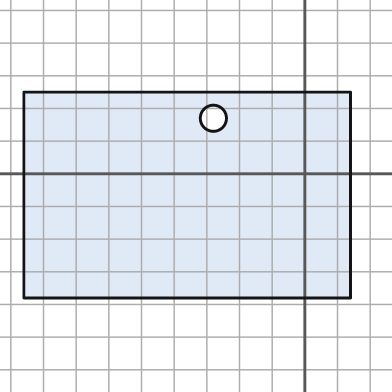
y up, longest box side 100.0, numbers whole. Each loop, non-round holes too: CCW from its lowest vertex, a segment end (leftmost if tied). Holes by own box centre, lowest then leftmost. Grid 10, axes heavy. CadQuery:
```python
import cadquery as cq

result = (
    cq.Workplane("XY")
    .moveTo(-86.0, -38.0)
    .lineTo(14.0, -38.0)
    .lineTo(14.0, 25.0)
    .lineTo(-86.0, 25.0)
    .close()
    .moveTo(-28.0, 17.0)
    .circle(4.0)
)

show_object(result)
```